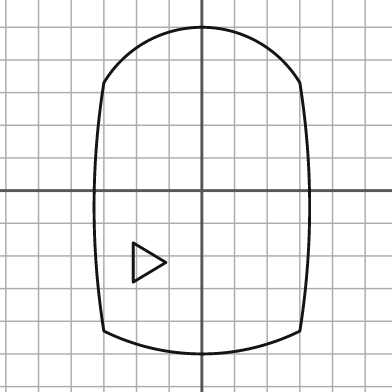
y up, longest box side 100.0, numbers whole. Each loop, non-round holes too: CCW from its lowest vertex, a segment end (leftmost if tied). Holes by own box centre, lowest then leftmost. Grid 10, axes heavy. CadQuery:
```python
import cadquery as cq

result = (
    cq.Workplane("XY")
    .moveTo(-30.0, -43.0)
    .threePointArc((0.0, -50.0), (30.0, -43.0))
    .threePointArc((33.0, -5.0), (30.0, 33.0))
    .threePointArc((0.0, 50.0), (-30.0, 33.0))
    .threePointArc((-33.0, -5.0), (-30.0, -43.0))
    .close()
    .moveTo(-21.0, -28.0)
    .lineTo(-11.0, -22.0)
    .lineTo(-21.0, -16.0)
    .close()
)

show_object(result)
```